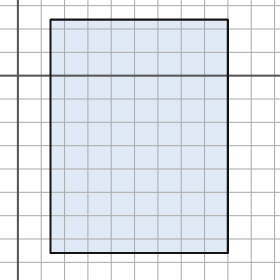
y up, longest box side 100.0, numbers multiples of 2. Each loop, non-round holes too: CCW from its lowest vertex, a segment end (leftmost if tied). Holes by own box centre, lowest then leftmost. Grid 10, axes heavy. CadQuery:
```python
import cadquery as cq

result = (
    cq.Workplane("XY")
    .moveTo(14.0, -76.0)
    .lineTo(90.0, -76.0)
    .lineTo(90.0, 24.0)
    .lineTo(14.0, 24.0)
    .close()
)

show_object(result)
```